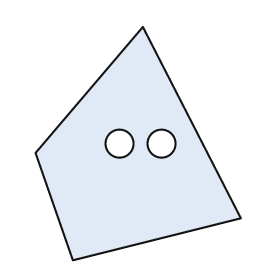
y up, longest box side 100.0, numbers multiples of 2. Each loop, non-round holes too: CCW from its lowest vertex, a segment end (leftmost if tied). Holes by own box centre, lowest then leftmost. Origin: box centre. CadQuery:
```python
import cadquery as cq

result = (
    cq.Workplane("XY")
    .moveTo(-28.0, -50.0)
    .lineTo(44.0, -32.0)
    .lineTo(2.0, 50.0)
    .lineTo(-44.0, -4.0)
    .close()
    .moveTo(-8.0, 0.0)
    .circle(6.0)
    .moveTo(10.0, 0.0)
    .circle(6.0)
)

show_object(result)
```